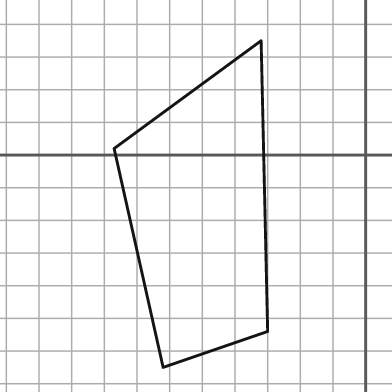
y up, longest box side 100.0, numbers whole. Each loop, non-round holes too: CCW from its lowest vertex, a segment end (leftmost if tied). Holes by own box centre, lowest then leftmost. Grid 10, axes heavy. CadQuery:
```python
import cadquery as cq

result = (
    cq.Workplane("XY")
    .moveTo(-62.0, -65.0)
    .lineTo(-30.0, -54.0)
    .lineTo(-32.0, 35.0)
    .lineTo(-77.0, 2.0)
    .close()
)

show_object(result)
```